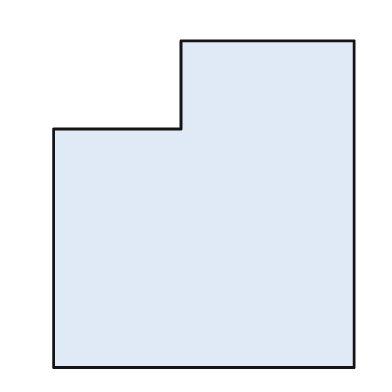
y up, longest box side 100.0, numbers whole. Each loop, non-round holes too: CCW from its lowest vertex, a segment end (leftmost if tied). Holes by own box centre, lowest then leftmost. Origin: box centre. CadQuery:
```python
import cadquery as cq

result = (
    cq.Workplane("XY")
    .moveTo(-46.0, -50.0)
    .lineTo(46.0, -50.0)
    .lineTo(46.0, 50.0)
    .lineTo(-7.0, 50.0)
    .lineTo(-7.0, 23.0)
    .lineTo(-46.0, 23.0)
    .close()
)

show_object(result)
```